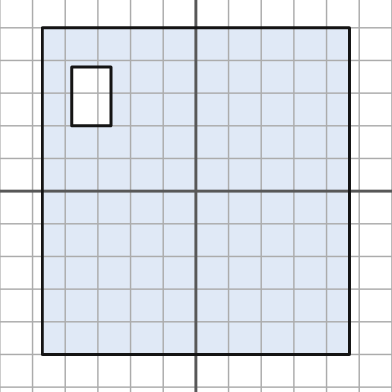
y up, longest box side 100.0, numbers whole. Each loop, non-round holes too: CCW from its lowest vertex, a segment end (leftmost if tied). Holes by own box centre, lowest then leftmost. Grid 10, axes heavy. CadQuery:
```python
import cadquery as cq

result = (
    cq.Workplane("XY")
    .moveTo(-47.0, -50.0)
    .lineTo(47.0, -50.0)
    .lineTo(47.0, 50.0)
    .lineTo(-47.0, 50.0)
    .close()
    .moveTo(-38.0, 20.0)
    .lineTo(-26.0, 20.0)
    .lineTo(-26.0, 38.0)
    .lineTo(-38.0, 38.0)
    .close()
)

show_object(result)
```